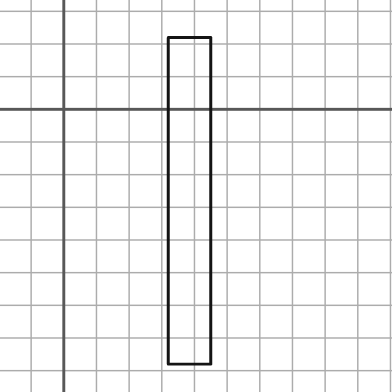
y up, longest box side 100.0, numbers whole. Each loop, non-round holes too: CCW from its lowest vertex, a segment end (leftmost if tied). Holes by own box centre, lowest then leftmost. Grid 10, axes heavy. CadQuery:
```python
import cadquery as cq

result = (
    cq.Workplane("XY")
    .moveTo(32.0, -78.0)
    .lineTo(45.0, -78.0)
    .lineTo(45.0, 22.0)
    .lineTo(32.0, 22.0)
    .close()
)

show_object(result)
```